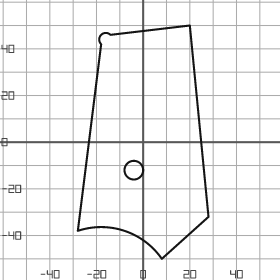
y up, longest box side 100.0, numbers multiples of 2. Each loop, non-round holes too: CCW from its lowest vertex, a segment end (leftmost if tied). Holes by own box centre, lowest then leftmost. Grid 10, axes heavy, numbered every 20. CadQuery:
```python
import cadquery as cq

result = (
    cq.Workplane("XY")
    .moveTo(8.0, -50.0)
    .lineTo(28.0, -32.0)
    .lineTo(20.0, 50.0)
    .lineTo(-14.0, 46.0)
    .threePointArc((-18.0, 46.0), (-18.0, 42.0))
    .lineTo(-28.0, -38.0)
    .threePointArc((-8.0, -38.0), (8.0, -50.0))
    .close()
    .moveTo(-4.0, -12.0)
    .circle(4.0)
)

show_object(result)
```